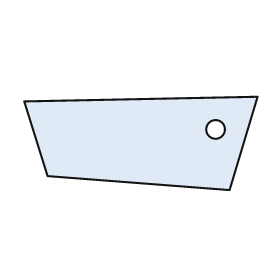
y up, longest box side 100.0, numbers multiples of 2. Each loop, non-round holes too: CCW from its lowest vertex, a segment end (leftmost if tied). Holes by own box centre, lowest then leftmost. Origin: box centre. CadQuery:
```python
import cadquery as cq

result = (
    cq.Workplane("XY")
    .moveTo(38.0, -20.0)
    .lineTo(50.0, 20.0)
    .lineTo(-50.0, 18.0)
    .lineTo(-40.0, -14.0)
    .close()
    .moveTo(32.0, 6.0)
    .circle(4.0)
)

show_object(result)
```